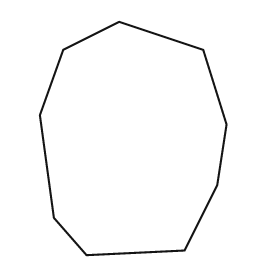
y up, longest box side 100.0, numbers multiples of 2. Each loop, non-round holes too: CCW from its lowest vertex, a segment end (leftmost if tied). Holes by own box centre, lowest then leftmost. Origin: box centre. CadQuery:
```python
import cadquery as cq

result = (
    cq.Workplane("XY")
    .moveTo(-20.0, -50.0)
    .lineTo(22.0, -48.0)
    .lineTo(36.0, -20.0)
    .lineTo(40.0, 6.0)
    .lineTo(30.0, 38.0)
    .lineTo(-6.0, 50.0)
    .lineTo(-30.0, 38.0)
    .lineTo(-40.0, 10.0)
    .lineTo(-34.0, -34.0)
    .close()
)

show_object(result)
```